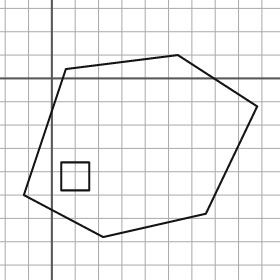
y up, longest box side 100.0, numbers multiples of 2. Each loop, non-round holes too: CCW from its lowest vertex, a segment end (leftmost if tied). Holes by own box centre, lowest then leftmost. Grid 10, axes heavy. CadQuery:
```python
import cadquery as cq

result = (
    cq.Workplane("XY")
    .moveTo(22.0, -68.0)
    .lineTo(66.0, -58.0)
    .lineTo(88.0, -12.0)
    .lineTo(54.0, 10.0)
    .lineTo(6.0, 4.0)
    .lineTo(-12.0, -50.0)
    .close()
    .moveTo(4.0, -48.0)
    .lineTo(16.0, -48.0)
    .lineTo(16.0, -36.0)
    .lineTo(4.0, -36.0)
    .close()
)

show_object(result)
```